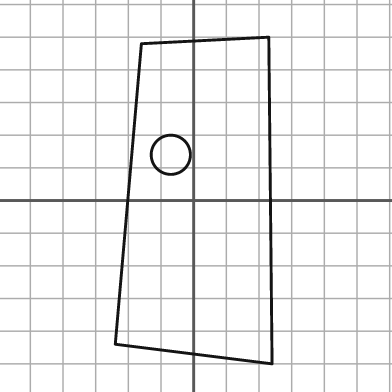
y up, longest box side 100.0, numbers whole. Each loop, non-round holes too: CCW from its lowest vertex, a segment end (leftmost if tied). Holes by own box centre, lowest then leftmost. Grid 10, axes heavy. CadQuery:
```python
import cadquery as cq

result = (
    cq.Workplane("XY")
    .moveTo(24.0, -50.0)
    .lineTo(23.0, 50.0)
    .lineTo(-16.0, 48.0)
    .lineTo(-24.0, -44.0)
    .close()
    .moveTo(-7.0, 14.0)
    .circle(6.0)
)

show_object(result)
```